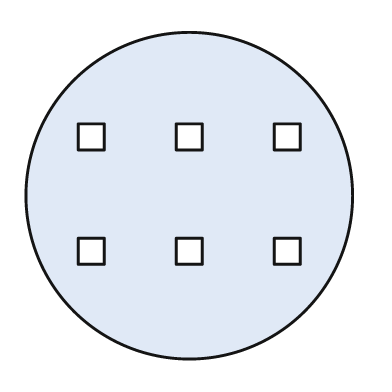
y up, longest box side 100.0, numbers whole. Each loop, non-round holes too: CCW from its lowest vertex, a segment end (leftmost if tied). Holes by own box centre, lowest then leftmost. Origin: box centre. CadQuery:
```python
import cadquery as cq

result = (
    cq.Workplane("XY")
    .moveTo(0.0, 0.0)
    .circle(50.0)
    .moveTo(-34.0, -21.0)
    .lineTo(-26.0, -21.0)
    .lineTo(-26.0, -13.0)
    .lineTo(-34.0, -13.0)
    .close()
    .moveTo(-4.0, -21.0)
    .lineTo(4.0, -21.0)
    .lineTo(4.0, -13.0)
    .lineTo(-4.0, -13.0)
    .close()
    .moveTo(26.0, -21.0)
    .lineTo(34.0, -21.0)
    .lineTo(34.0, -13.0)
    .lineTo(26.0, -13.0)
    .close()
    .moveTo(-34.0, 14.0)
    .lineTo(-26.0, 14.0)
    .lineTo(-26.0, 22.0)
    .lineTo(-34.0, 22.0)
    .close()
    .moveTo(-4.0, 14.0)
    .lineTo(4.0, 14.0)
    .lineTo(4.0, 22.0)
    .lineTo(-4.0, 22.0)
    .close()
    .moveTo(26.0, 14.0)
    .lineTo(34.0, 14.0)
    .lineTo(34.0, 22.0)
    .lineTo(26.0, 22.0)
    .close()
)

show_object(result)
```